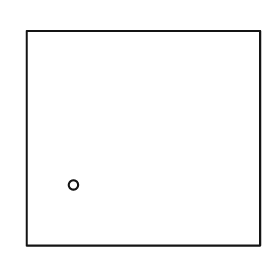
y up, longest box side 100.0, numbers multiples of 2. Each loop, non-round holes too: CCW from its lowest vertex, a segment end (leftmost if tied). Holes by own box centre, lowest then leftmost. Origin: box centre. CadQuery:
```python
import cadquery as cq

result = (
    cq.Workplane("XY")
    .moveTo(-50.0, -46.0)
    .lineTo(50.0, -46.0)
    .lineTo(50.0, 46.0)
    .lineTo(-50.0, 46.0)
    .close()
    .moveTo(-30.0, -20.0)
    .circle(2.0)
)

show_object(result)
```